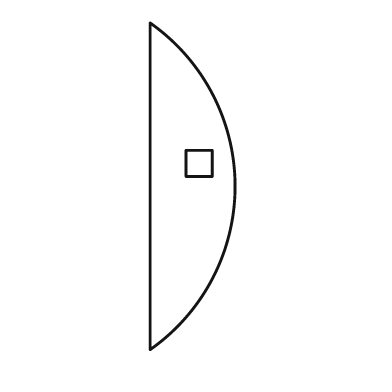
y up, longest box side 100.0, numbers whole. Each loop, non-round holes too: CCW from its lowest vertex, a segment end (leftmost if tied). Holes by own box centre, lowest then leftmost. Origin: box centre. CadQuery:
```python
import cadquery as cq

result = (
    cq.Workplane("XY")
    .moveTo(-13.0, -50.0)
    .threePointArc((13.0, 0.0), (-13.0, 50.0))
    .close()
    .moveTo(-2.0, 3.0)
    .lineTo(6.0, 3.0)
    .lineTo(6.0, 11.0)
    .lineTo(-2.0, 11.0)
    .close()
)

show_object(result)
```